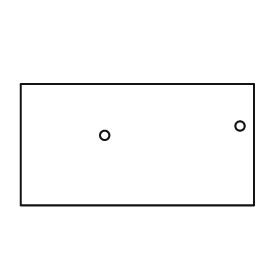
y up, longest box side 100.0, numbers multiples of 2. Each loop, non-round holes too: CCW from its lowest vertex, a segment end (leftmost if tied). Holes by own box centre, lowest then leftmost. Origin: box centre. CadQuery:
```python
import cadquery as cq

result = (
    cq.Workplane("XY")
    .moveTo(-50.0, -26.0)
    .lineTo(50.0, -26.0)
    .lineTo(50.0, 26.0)
    .lineTo(-50.0, 26.0)
    .close()
    .moveTo(-14.0, 4.0)
    .circle(2.0)
    .moveTo(44.0, 8.0)
    .circle(2.0)
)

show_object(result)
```